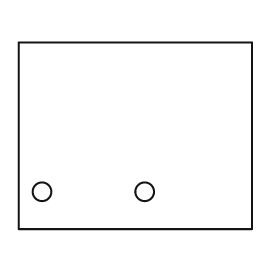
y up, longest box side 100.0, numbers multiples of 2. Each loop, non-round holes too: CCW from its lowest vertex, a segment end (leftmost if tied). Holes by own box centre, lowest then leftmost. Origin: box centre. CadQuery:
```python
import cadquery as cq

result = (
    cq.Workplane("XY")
    .moveTo(-50.0, -40.0)
    .lineTo(50.0, -40.0)
    .lineTo(50.0, 40.0)
    .lineTo(-50.0, 40.0)
    .close()
    .moveTo(-40.0, -24.0)
    .circle(4.0)
    .moveTo(4.0, -24.0)
    .circle(4.0)
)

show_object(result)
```